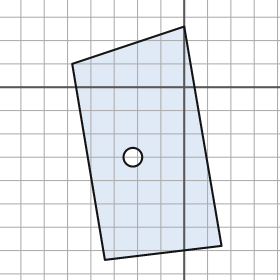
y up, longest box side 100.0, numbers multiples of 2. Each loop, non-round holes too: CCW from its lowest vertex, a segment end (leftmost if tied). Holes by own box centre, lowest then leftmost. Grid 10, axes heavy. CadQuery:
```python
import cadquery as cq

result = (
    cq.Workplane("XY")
    .moveTo(-34.0, -74.0)
    .lineTo(16.0, -68.0)
    .lineTo(0.0, 26.0)
    .lineTo(-48.0, 10.0)
    .close()
    .moveTo(-22.0, -30.0)
    .circle(4.0)
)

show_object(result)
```